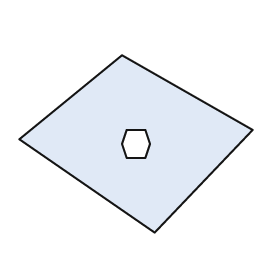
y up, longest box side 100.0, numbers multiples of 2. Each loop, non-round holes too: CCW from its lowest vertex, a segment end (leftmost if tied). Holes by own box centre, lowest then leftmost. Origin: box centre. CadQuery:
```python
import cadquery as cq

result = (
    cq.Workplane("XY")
    .moveTo(8.0, -38.0)
    .lineTo(50.0, 6.0)
    .lineTo(-6.0, 38.0)
    .lineTo(-50.0, 2.0)
    .close()
    .moveTo(-4.0, -6.0)
    .lineTo(4.0, -6.0)
    .lineTo(6.0, 0.0)
    .lineTo(4.0, 6.0)
    .lineTo(-4.0, 6.0)
    .lineTo(-6.0, 0.0)
    .close()
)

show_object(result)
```